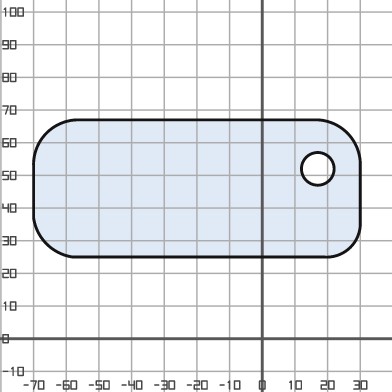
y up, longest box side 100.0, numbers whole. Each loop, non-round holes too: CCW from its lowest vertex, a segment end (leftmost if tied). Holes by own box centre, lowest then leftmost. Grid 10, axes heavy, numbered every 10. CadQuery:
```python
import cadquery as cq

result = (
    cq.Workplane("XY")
    .moveTo(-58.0, 25.0)
    .lineTo(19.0, 25.0)
    .threePointArc((27.0, 28.0), (30.0, 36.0))
    .lineTo(30.0, 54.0)
    .threePointArc((26.0, 63.0), (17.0, 67.0))
    .lineTo(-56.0, 67.0)
    .threePointArc((-66.0, 63.0), (-70.0, 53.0))
    .lineTo(-70.0, 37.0)
    .threePointArc((-66.0, 29.0), (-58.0, 25.0))
    .close()
    .moveTo(17.0, 52.0)
    .circle(5.0)
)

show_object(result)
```